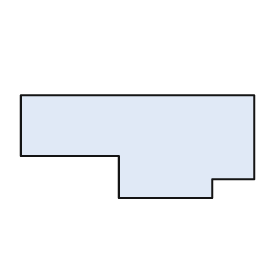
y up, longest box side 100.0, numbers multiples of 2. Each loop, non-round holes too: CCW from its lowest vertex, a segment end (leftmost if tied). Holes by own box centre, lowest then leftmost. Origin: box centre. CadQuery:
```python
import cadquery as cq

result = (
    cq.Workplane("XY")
    .moveTo(-8.0, -22.0)
    .lineTo(32.0, -22.0)
    .lineTo(32.0, -14.0)
    .lineTo(50.0, -14.0)
    .lineTo(50.0, 22.0)
    .lineTo(-50.0, 22.0)
    .lineTo(-50.0, -4.0)
    .lineTo(-8.0, -4.0)
    .close()
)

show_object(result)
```